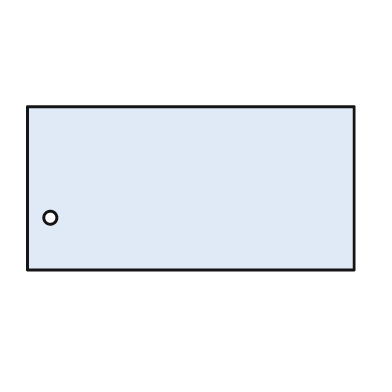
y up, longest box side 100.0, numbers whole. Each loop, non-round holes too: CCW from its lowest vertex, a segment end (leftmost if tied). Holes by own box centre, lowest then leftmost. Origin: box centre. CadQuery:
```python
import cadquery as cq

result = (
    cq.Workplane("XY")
    .moveTo(-50.0, -25.0)
    .lineTo(50.0, -25.0)
    .lineTo(50.0, 25.0)
    .lineTo(-50.0, 25.0)
    .close()
    .moveTo(-43.0, -9.0)
    .circle(2.0)
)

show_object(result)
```